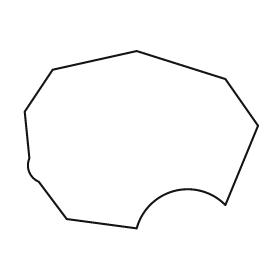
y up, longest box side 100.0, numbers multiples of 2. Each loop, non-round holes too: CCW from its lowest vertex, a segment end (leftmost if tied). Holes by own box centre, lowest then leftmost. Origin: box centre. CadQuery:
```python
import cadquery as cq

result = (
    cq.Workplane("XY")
    .moveTo(-2.0, -38.0)
    .threePointArc((14.0, -22.0), (36.0, -28.0))
    .lineTo(50.0, 6.0)
    .lineTo(36.0, 26.0)
    .lineTo(-2.0, 38.0)
    .lineTo(-38.0, 30.0)
    .lineTo(-50.0, 12.0)
    .lineTo(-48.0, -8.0)
    .threePointArc((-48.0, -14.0), (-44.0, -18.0))
    .lineTo(-32.0, -34.0)
    .close()
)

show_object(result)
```